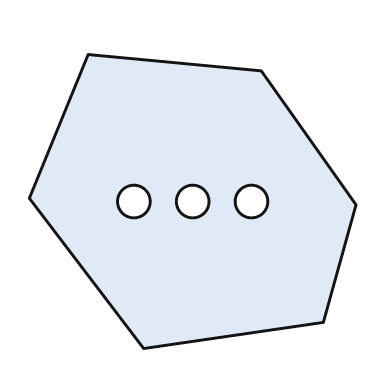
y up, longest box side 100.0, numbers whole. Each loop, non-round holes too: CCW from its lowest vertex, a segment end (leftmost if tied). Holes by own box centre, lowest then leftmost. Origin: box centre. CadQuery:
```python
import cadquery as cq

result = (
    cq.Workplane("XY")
    .moveTo(-15.0, -45.0)
    .lineTo(40.0, -37.0)
    .lineTo(50.0, -1.0)
    .lineTo(21.0, 40.0)
    .lineTo(-32.0, 45.0)
    .lineTo(-50.0, 1.0)
    .close()
    .moveTo(-18.0, 0.0)
    .circle(5.0)
    .moveTo(0.0, 0.0)
    .circle(5.0)
    .moveTo(18.0, 0.0)
    .circle(5.0)
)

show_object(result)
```